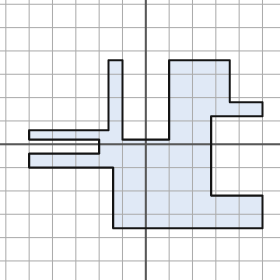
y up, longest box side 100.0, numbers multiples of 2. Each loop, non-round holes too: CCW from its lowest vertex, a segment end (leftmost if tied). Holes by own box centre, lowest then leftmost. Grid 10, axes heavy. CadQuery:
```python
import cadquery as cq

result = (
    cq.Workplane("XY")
    .moveTo(-14.0, -36.0)
    .lineTo(50.0, -36.0)
    .lineTo(50.0, -22.0)
    .lineTo(28.0, -22.0)
    .lineTo(28.0, 12.0)
    .lineTo(50.0, 12.0)
    .lineTo(50.0, 18.0)
    .lineTo(36.0, 18.0)
    .lineTo(36.0, 36.0)
    .lineTo(10.0, 36.0)
    .lineTo(10.0, 2.0)
    .lineTo(-10.0, 2.0)
    .lineTo(-10.0, 36.0)
    .lineTo(-16.0, 36.0)
    .lineTo(-16.0, 6.0)
    .lineTo(-50.0, 6.0)
    .lineTo(-50.0, 2.0)
    .lineTo(-20.0, 2.0)
    .lineTo(-20.0, -4.0)
    .lineTo(-50.0, -4.0)
    .lineTo(-50.0, -10.0)
    .lineTo(-14.0, -10.0)
    .close()
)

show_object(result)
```